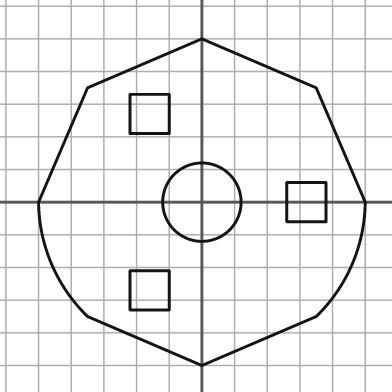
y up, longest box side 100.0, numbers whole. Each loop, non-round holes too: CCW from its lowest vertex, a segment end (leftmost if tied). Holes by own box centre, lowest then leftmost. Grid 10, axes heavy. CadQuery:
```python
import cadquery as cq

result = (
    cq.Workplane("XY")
    .moveTo(0.0, -50.0)
    .lineTo(35.0, -35.0)
    .threePointArc((46.0, -19.0), (50.0, 0.0))
    .lineTo(35.0, 35.0)
    .lineTo(0.0, 50.0)
    .lineTo(-35.0, 35.0)
    .lineTo(-50.0, 0.0)
    .threePointArc((-46.0, -19.0), (-35.0, -35.0))
    .close()
    .moveTo(-22.0, -33.0)
    .lineTo(-10.0, -33.0)
    .lineTo(-10.0, -21.0)
    .lineTo(-22.0, -21.0)
    .close()
    .moveTo(0.0, 0.0)
    .circle(12.0)
    .moveTo(26.0, -6.0)
    .lineTo(38.0, -6.0)
    .lineTo(38.0, 6.0)
    .lineTo(26.0, 6.0)
    .close()
    .moveTo(-22.0, 21.0)
    .lineTo(-10.0, 21.0)
    .lineTo(-10.0, 33.0)
    .lineTo(-22.0, 33.0)
    .close()
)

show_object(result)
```